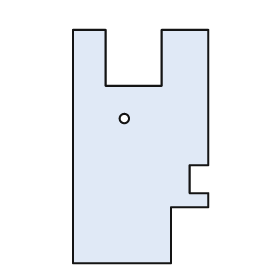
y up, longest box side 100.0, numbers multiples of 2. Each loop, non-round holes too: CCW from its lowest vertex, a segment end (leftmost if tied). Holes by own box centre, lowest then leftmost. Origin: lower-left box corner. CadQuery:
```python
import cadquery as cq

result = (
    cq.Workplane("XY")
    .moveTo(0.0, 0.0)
    .lineTo(42.0, 0.0)
    .lineTo(42.0, 24.0)
    .lineTo(58.0, 24.0)
    .lineTo(58.0, 30.0)
    .lineTo(50.0, 30.0)
    .lineTo(50.0, 42.0)
    .lineTo(58.0, 42.0)
    .lineTo(58.0, 100.0)
    .lineTo(38.0, 100.0)
    .lineTo(38.0, 76.0)
    .lineTo(14.0, 76.0)
    .lineTo(14.0, 100.0)
    .lineTo(0.0, 100.0)
    .close()
    .moveTo(22.0, 62.0)
    .circle(2.0)
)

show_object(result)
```